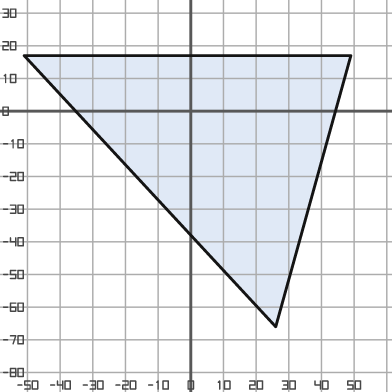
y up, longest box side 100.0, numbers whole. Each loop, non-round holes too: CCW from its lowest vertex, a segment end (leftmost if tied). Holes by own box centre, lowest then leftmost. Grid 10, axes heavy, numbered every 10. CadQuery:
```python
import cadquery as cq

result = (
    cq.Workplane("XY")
    .moveTo(26.0, -66.0)
    .lineTo(49.0, 17.0)
    .lineTo(-51.0, 17.0)
    .close()
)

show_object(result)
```